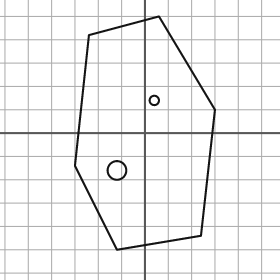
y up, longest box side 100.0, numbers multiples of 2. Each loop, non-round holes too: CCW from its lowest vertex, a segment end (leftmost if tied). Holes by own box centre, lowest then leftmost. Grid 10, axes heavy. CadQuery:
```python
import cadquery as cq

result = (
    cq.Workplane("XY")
    .moveTo(-12.0, -50.0)
    .lineTo(24.0, -44.0)
    .lineTo(30.0, 10.0)
    .lineTo(6.0, 50.0)
    .lineTo(-24.0, 42.0)
    .lineTo(-30.0, -14.0)
    .close()
    .moveTo(-12.0, -16.0)
    .circle(4.0)
    .moveTo(4.0, 14.0)
    .circle(2.0)
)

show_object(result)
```